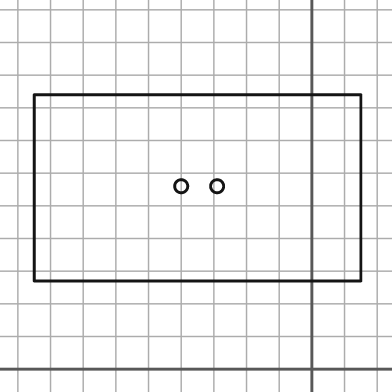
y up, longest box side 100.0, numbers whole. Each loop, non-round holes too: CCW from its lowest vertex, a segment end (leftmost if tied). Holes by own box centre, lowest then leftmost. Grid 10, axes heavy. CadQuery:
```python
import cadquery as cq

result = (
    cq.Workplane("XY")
    .moveTo(-85.0, 27.0)
    .lineTo(15.0, 27.0)
    .lineTo(15.0, 84.0)
    .lineTo(-85.0, 84.0)
    .close()
    .moveTo(-40.0, 56.0)
    .circle(2.0)
    .moveTo(-29.0, 56.0)
    .circle(2.0)
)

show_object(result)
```